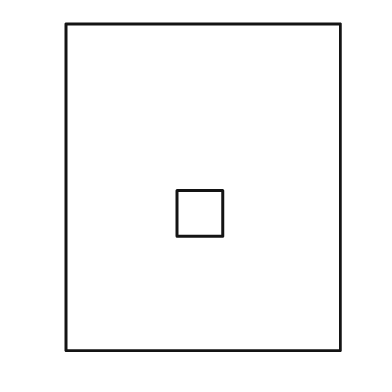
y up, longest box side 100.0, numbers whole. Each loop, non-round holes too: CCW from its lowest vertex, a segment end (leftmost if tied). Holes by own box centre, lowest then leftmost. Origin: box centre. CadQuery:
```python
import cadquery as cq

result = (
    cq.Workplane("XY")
    .moveTo(-42.0, -50.0)
    .lineTo(42.0, -50.0)
    .lineTo(42.0, 50.0)
    .lineTo(-42.0, 50.0)
    .close()
    .moveTo(-8.0, -15.0)
    .lineTo(6.0, -15.0)
    .lineTo(6.0, -1.0)
    .lineTo(-8.0, -1.0)
    .close()
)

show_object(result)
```